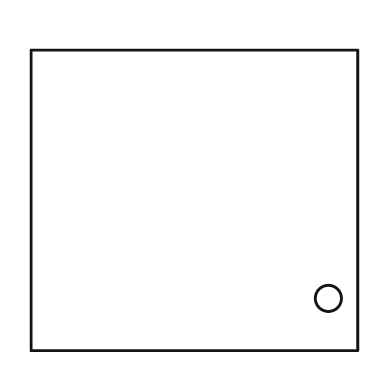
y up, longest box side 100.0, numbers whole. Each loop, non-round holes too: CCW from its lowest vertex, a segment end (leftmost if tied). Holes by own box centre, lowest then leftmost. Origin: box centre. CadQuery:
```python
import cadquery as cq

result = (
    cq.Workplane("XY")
    .moveTo(-50.0, -46.0)
    .lineTo(50.0, -46.0)
    .lineTo(50.0, 46.0)
    .lineTo(-50.0, 46.0)
    .close()
    .moveTo(41.0, -30.0)
    .circle(4.0)
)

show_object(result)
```